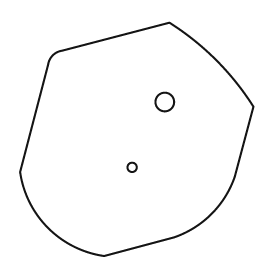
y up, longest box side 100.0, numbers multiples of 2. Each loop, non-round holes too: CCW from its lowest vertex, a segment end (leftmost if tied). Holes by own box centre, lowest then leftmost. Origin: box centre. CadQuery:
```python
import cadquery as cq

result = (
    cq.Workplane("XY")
    .moveTo(-14.0, -50.0)
    .lineTo(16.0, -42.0)
    .threePointArc((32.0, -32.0), (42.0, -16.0))
    .lineTo(50.0, 14.0)
    .threePointArc((34.0, 34.0), (14.0, 50.0))
    .lineTo(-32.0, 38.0)
    .threePointArc((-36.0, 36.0), (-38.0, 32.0))
    .lineTo(-50.0, -14.0)
    .threePointArc((-38.0, -38.0), (-14.0, -50.0))
    .close()
    .moveTo(-2.0, -12.0)
    .circle(2.0)
    .moveTo(12.0, 16.0)
    .circle(4.0)
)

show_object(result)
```